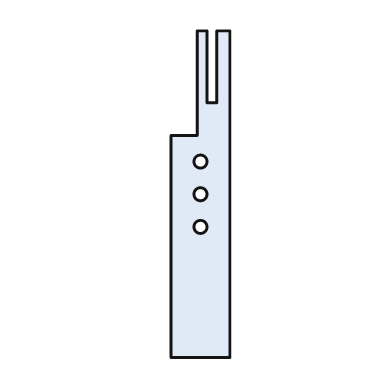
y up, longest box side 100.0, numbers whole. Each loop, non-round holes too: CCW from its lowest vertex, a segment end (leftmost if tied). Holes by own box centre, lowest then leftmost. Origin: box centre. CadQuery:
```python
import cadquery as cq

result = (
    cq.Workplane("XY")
    .moveTo(-9.0, -50.0)
    .lineTo(9.0, -50.0)
    .lineTo(9.0, 50.0)
    .lineTo(5.0, 50.0)
    .lineTo(5.0, 28.0)
    .lineTo(2.0, 28.0)
    .lineTo(2.0, 50.0)
    .lineTo(-1.0, 50.0)
    .lineTo(-1.0, 18.0)
    .lineTo(-9.0, 18.0)
    .close()
    .moveTo(0.0, -10.0)
    .circle(2.0)
    .moveTo(0.0, 0.0)
    .circle(2.0)
    .moveTo(0.0, 10.0)
    .circle(2.0)
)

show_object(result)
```